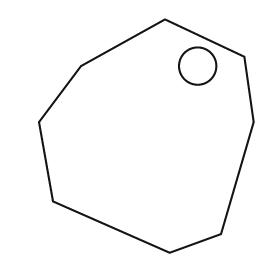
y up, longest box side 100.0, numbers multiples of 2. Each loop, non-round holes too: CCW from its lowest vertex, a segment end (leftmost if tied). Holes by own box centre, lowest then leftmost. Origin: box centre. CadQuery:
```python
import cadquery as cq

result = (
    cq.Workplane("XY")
    .moveTo(10.0, -50.0)
    .lineTo(32.0, -42.0)
    .lineTo(46.0, 6.0)
    .lineTo(42.0, 34.0)
    .lineTo(8.0, 50.0)
    .lineTo(-28.0, 30.0)
    .lineTo(-46.0, 6.0)
    .lineTo(-40.0, -28.0)
    .close()
    .moveTo(22.0, 30.0)
    .circle(8.0)
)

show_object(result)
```